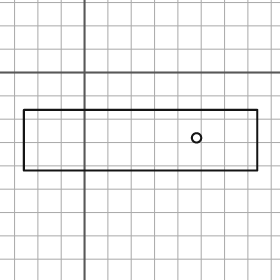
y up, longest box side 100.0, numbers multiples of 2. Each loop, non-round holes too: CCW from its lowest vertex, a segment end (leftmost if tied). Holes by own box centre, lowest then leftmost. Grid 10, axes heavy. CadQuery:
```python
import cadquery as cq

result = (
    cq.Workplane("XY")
    .moveTo(-26.0, -42.0)
    .lineTo(74.0, -42.0)
    .lineTo(74.0, -16.0)
    .lineTo(-26.0, -16.0)
    .close()
    .moveTo(48.0, -28.0)
    .circle(2.0)
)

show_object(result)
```